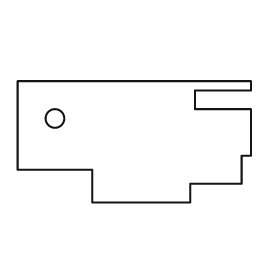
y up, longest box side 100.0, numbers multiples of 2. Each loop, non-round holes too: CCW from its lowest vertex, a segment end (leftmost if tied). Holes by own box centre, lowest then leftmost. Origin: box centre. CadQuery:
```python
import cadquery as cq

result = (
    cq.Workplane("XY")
    .moveTo(-18.0, -26.0)
    .lineTo(24.0, -26.0)
    .lineTo(24.0, -18.0)
    .lineTo(46.0, -18.0)
    .lineTo(46.0, -6.0)
    .lineTo(50.0, -6.0)
    .lineTo(50.0, 14.0)
    .lineTo(26.0, 14.0)
    .lineTo(26.0, 22.0)
    .lineTo(50.0, 22.0)
    .lineTo(50.0, 26.0)
    .lineTo(-50.0, 26.0)
    .lineTo(-50.0, -12.0)
    .lineTo(-18.0, -12.0)
    .close()
    .moveTo(-34.0, 10.0)
    .circle(4.0)
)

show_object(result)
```